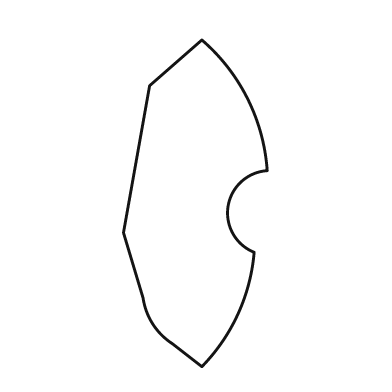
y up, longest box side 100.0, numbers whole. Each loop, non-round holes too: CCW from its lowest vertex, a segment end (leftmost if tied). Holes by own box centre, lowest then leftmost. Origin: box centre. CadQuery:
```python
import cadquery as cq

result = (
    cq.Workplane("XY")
    .moveTo(2.0, -50.0)
    .threePointArc((13.0, -34.0), (18.0, -15.0))
    .threePointArc((10.0, -1.0), (22.0, 10.0))
    .threePointArc((16.0, 32.0), (2.0, 50.0))
    .lineTo(-14.0, 36.0)
    .lineTo(-22.0, -9.0)
    .lineTo(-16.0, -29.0)
    .threePointArc((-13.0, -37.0), (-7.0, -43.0))
    .close()
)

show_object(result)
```